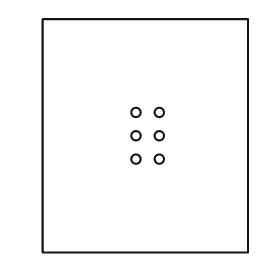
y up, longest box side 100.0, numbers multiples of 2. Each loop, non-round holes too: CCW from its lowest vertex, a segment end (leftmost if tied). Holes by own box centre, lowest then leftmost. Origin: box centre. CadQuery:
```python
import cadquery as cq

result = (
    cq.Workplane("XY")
    .moveTo(-44.0, -50.0)
    .lineTo(44.0, -50.0)
    .lineTo(44.0, 50.0)
    .lineTo(-44.0, 50.0)
    .close()
    .moveTo(-4.0, -10.0)
    .circle(2.0)
    .moveTo(6.0, -10.0)
    .circle(2.0)
    .moveTo(-4.0, 0.0)
    .circle(2.0)
    .moveTo(6.0, 0.0)
    .circle(2.0)
    .moveTo(-4.0, 10.0)
    .circle(2.0)
    .moveTo(6.0, 10.0)
    .circle(2.0)
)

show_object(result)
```